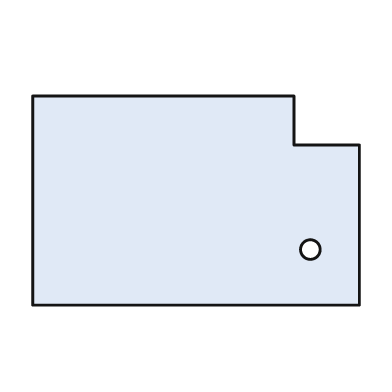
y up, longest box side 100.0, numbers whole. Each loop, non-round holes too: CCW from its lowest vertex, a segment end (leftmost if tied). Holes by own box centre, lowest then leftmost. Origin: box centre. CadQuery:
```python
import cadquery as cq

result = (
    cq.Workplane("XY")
    .moveTo(-50.0, -32.0)
    .lineTo(50.0, -32.0)
    .lineTo(50.0, 17.0)
    .lineTo(30.0, 17.0)
    .lineTo(30.0, 32.0)
    .lineTo(-50.0, 32.0)
    .close()
    .moveTo(35.0, -15.0)
    .circle(3.0)
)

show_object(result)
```